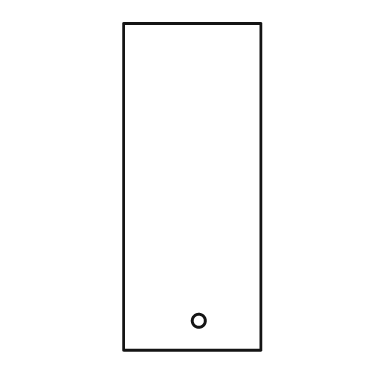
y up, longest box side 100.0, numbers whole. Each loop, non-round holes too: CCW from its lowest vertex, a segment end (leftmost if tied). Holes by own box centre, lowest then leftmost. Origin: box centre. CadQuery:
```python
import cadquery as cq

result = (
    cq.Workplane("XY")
    .moveTo(-21.0, -50.0)
    .lineTo(21.0, -50.0)
    .lineTo(21.0, 50.0)
    .lineTo(-21.0, 50.0)
    .close()
    .moveTo(2.0, -41.0)
    .circle(2.0)
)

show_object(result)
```